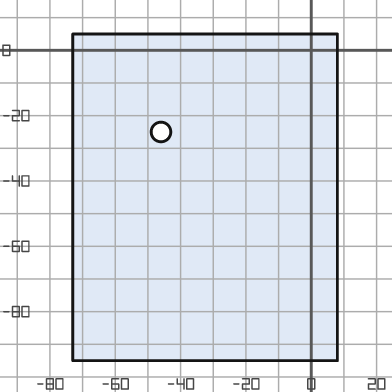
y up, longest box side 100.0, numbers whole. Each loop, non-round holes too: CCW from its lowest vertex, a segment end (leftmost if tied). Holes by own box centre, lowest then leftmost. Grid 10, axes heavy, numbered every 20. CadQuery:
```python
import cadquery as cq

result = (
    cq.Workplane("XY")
    .moveTo(-73.0, -95.0)
    .lineTo(8.0, -95.0)
    .lineTo(8.0, 5.0)
    .lineTo(-73.0, 5.0)
    .close()
    .moveTo(-46.0, -25.0)
    .circle(3.0)
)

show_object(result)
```